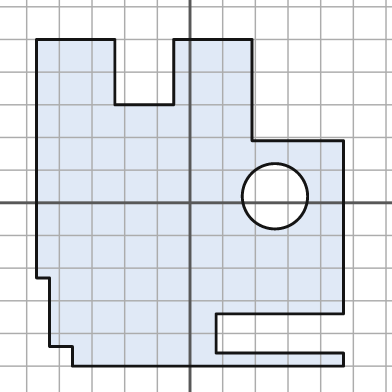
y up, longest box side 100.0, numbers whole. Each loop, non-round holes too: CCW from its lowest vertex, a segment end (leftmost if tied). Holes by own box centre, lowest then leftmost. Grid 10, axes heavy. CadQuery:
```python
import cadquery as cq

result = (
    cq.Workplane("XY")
    .moveTo(-36.0, -50.0)
    .lineTo(47.0, -50.0)
    .lineTo(47.0, -46.0)
    .lineTo(8.0, -46.0)
    .lineTo(8.0, -34.0)
    .lineTo(47.0, -34.0)
    .lineTo(47.0, 19.0)
    .lineTo(19.0, 19.0)
    .lineTo(19.0, 50.0)
    .lineTo(-5.0, 50.0)
    .lineTo(-5.0, 30.0)
    .lineTo(-23.0, 30.0)
    .lineTo(-23.0, 50.0)
    .lineTo(-47.0, 50.0)
    .lineTo(-47.0, -23.0)
    .lineTo(-43.0, -23.0)
    .lineTo(-43.0, -44.0)
    .lineTo(-36.0, -44.0)
    .close()
    .moveTo(26.0, 2.0)
    .circle(10.0)
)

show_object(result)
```